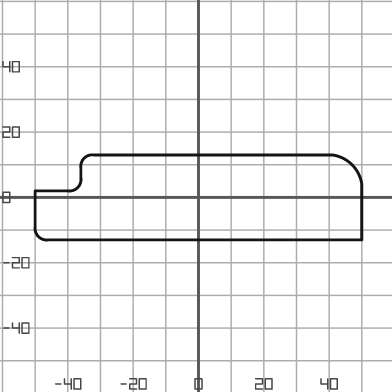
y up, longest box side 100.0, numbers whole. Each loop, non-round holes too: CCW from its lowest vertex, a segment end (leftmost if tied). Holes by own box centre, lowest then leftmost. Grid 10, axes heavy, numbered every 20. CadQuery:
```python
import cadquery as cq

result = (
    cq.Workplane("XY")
    .moveTo(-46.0, -13.0)
    .lineTo(50.0, -13.0)
    .lineTo(50.0, 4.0)
    .threePointArc((47.0, 10.0), (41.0, 13.0))
    .lineTo(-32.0, 13.0)
    .threePointArc((-35.0, 12.0), (-36.0, 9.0))
    .lineTo(-36.0, 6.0)
    .threePointArc((-37.0, 3.0), (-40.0, 2.0))
    .lineTo(-50.0, 2.0)
    .lineTo(-50.0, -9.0)
    .threePointArc((-49.0, -12.0), (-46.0, -13.0))
    .close()
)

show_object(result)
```